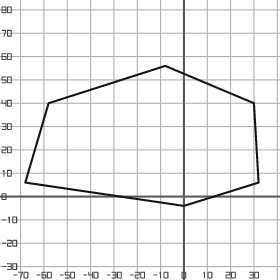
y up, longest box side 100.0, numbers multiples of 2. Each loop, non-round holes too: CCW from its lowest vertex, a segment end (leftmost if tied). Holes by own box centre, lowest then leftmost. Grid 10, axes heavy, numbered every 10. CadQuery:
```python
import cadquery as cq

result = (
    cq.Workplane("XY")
    .moveTo(0.0, -4.0)
    .lineTo(32.0, 6.0)
    .lineTo(30.0, 40.0)
    .lineTo(-8.0, 56.0)
    .lineTo(-58.0, 40.0)
    .lineTo(-68.0, 6.0)
    .close()
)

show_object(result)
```